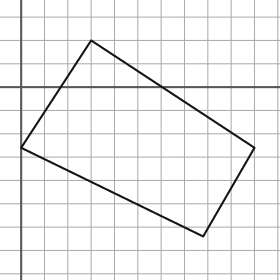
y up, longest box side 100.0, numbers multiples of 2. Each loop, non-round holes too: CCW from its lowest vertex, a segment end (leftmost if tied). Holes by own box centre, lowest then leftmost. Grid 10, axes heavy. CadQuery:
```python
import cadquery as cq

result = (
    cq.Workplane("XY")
    .moveTo(78.0, -64.0)
    .lineTo(100.0, -26.0)
    .lineTo(30.0, 20.0)
    .lineTo(0.0, -26.0)
    .close()
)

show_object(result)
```